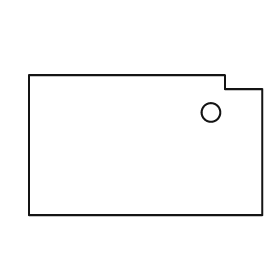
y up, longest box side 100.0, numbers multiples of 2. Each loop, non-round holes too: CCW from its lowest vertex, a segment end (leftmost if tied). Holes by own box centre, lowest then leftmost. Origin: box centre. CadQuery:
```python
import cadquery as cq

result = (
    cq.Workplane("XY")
    .moveTo(-50.0, -30.0)
    .lineTo(50.0, -30.0)
    .lineTo(50.0, 24.0)
    .lineTo(34.0, 24.0)
    .lineTo(34.0, 30.0)
    .lineTo(-50.0, 30.0)
    .close()
    .moveTo(28.0, 14.0)
    .circle(4.0)
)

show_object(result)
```